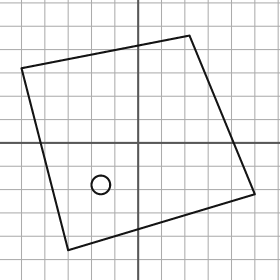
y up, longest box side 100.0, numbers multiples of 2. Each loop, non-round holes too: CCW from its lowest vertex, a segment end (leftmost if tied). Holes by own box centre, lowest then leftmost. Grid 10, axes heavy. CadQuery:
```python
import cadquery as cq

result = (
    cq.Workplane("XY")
    .moveTo(-30.0, -46.0)
    .lineTo(50.0, -22.0)
    .lineTo(22.0, 46.0)
    .lineTo(-50.0, 32.0)
    .close()
    .moveTo(-16.0, -18.0)
    .circle(4.0)
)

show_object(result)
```